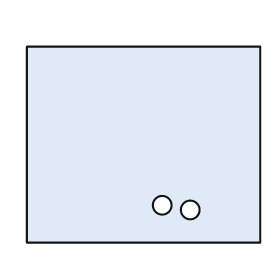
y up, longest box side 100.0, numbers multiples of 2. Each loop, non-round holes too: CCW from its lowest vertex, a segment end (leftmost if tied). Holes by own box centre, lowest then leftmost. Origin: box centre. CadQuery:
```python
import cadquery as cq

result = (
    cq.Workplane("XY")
    .moveTo(-50.0, -42.0)
    .lineTo(50.0, -42.0)
    .lineTo(50.0, 42.0)
    .lineTo(-50.0, 42.0)
    .close()
    .moveTo(20.0, -28.0)
    .circle(4.0)
    .moveTo(8.0, -26.0)
    .circle(4.0)
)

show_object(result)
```